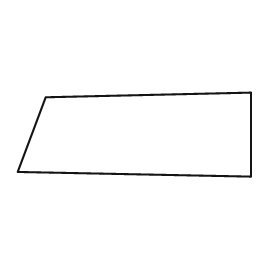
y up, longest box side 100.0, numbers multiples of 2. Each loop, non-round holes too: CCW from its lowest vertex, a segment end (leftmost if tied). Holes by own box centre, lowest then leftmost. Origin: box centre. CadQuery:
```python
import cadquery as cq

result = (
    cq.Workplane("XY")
    .moveTo(50.0, -18.0)
    .lineTo(50.0, 18.0)
    .lineTo(-38.0, 16.0)
    .lineTo(-50.0, -16.0)
    .close()
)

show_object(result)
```